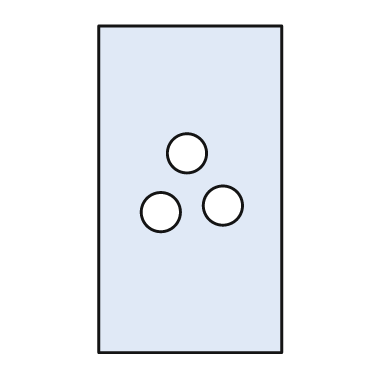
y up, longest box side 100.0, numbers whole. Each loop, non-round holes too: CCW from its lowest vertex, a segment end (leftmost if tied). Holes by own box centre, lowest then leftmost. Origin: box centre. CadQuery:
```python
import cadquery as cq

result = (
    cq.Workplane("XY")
    .moveTo(-28.0, -50.0)
    .lineTo(28.0, -50.0)
    .lineTo(28.0, 50.0)
    .lineTo(-28.0, 50.0)
    .close()
    .moveTo(-9.0, -7.0)
    .circle(6.0)
    .moveTo(10.0, -5.0)
    .circle(6.0)
    .moveTo(-1.0, 11.0)
    .circle(6.0)
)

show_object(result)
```